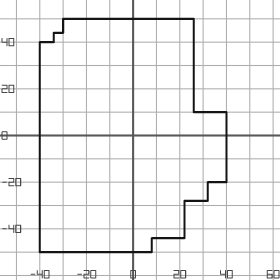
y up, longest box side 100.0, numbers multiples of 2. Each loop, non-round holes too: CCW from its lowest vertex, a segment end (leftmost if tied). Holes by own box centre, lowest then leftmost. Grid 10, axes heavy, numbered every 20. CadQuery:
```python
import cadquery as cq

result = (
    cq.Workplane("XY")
    .moveTo(-40.0, -50.0)
    .lineTo(8.0, -50.0)
    .lineTo(8.0, -44.0)
    .lineTo(22.0, -44.0)
    .lineTo(22.0, -28.0)
    .lineTo(32.0, -28.0)
    .lineTo(32.0, -20.0)
    .lineTo(40.0, -20.0)
    .lineTo(40.0, 10.0)
    .lineTo(26.0, 10.0)
    .lineTo(26.0, 50.0)
    .lineTo(-30.0, 50.0)
    .lineTo(-30.0, 44.0)
    .lineTo(-34.0, 44.0)
    .lineTo(-34.0, 40.0)
    .lineTo(-40.0, 40.0)
    .close()
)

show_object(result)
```